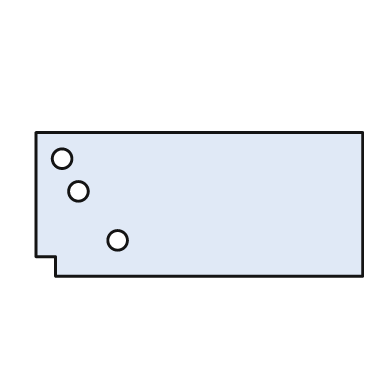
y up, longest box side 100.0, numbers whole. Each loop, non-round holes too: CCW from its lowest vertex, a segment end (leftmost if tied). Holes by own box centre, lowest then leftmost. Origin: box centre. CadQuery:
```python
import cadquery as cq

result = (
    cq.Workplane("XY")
    .moveTo(-44.0, -22.0)
    .lineTo(50.0, -22.0)
    .lineTo(50.0, 22.0)
    .lineTo(-50.0, 22.0)
    .lineTo(-50.0, -16.0)
    .lineTo(-44.0, -16.0)
    .close()
    .moveTo(-25.0, -11.0)
    .circle(3.0)
    .moveTo(-37.0, 4.0)
    .circle(3.0)
    .moveTo(-42.0, 14.0)
    .circle(3.0)
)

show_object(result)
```